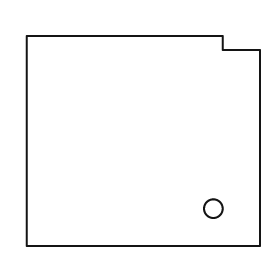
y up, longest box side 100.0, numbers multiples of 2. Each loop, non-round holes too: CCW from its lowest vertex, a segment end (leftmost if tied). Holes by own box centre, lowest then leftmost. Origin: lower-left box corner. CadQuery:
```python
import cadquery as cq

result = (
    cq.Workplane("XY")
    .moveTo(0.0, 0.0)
    .lineTo(100.0, 0.0)
    .lineTo(100.0, 84.0)
    .lineTo(84.0, 84.0)
    .lineTo(84.0, 90.0)
    .lineTo(0.0, 90.0)
    .close()
    .moveTo(80.0, 16.0)
    .circle(4.0)
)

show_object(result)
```